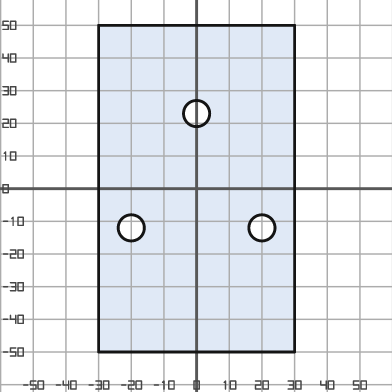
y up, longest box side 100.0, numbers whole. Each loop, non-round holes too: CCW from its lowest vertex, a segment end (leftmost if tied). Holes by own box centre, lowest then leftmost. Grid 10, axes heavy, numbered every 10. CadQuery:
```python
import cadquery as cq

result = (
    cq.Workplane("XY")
    .moveTo(-30.0, -50.0)
    .lineTo(30.0, -50.0)
    .lineTo(30.0, 50.0)
    .lineTo(-30.0, 50.0)
    .close()
    .moveTo(-20.0, -12.0)
    .circle(4.0)
    .moveTo(20.0, -12.0)
    .circle(4.0)
    .moveTo(0.0, 23.0)
    .circle(4.0)
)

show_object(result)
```